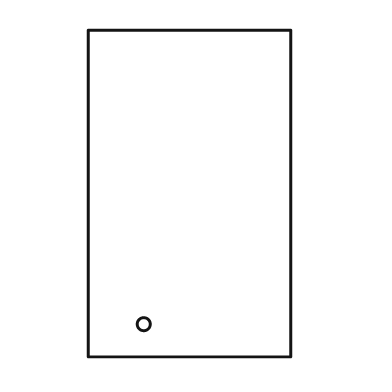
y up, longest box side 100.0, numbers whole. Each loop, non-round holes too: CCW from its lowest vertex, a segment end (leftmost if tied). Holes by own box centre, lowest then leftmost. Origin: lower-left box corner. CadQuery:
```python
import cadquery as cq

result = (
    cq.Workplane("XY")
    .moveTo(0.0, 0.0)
    .lineTo(62.0, 0.0)
    .lineTo(62.0, 100.0)
    .lineTo(0.0, 100.0)
    .close()
    .moveTo(17.0, 10.0)
    .circle(2.0)
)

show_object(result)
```